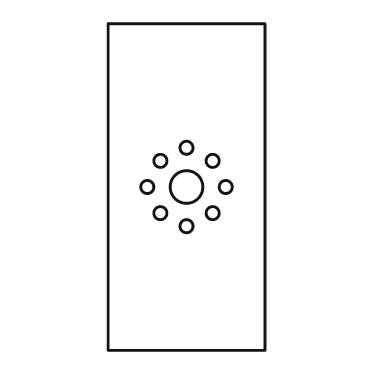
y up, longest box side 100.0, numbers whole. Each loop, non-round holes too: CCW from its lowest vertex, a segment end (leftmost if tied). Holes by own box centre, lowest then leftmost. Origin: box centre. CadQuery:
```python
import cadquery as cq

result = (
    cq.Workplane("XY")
    .moveTo(-24.0, -50.0)
    .lineTo(24.0, -50.0)
    .lineTo(24.0, 50.0)
    .lineTo(-24.0, 50.0)
    .close()
    .moveTo(0.0, -12.0)
    .circle(2.0)
    .moveTo(-8.0, -8.0)
    .circle(2.0)
    .moveTo(8.0, -8.0)
    .circle(2.0)
    .moveTo(-12.0, 0.0)
    .circle(2.0)
    .moveTo(0.0, 0.0)
    .circle(5.0)
    .moveTo(12.0, 0.0)
    .circle(2.0)
    .moveTo(-8.0, 8.0)
    .circle(2.0)
    .moveTo(8.0, 8.0)
    .circle(2.0)
    .moveTo(0.0, 12.0)
    .circle(2.0)
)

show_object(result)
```